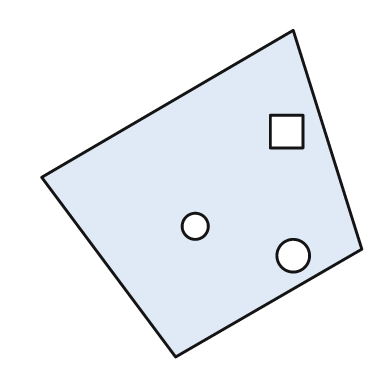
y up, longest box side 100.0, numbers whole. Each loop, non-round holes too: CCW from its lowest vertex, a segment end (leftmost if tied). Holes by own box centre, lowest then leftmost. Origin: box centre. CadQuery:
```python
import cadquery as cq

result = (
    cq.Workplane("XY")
    .moveTo(-8.0, -50.0)
    .lineTo(49.0, -17.0)
    .lineTo(28.0, 50.0)
    .lineTo(-49.0, 5.0)
    .close()
    .moveTo(28.0, -19.0)
    .circle(5.0)
    .moveTo(-2.0, -10.0)
    .circle(4.0)
    .moveTo(21.0, 14.0)
    .lineTo(31.0, 14.0)
    .lineTo(31.0, 24.0)
    .lineTo(21.0, 24.0)
    .close()
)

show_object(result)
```